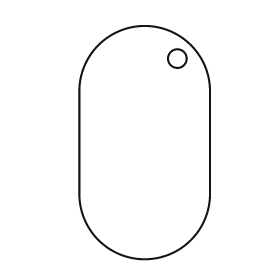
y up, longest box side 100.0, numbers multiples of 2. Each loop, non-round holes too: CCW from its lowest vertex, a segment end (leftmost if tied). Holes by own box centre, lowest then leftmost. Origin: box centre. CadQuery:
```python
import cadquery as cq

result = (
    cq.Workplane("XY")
    .moveTo(-28.0, -22.0)
    .threePointArc((0.0, -50.0), (28.0, -22.0))
    .lineTo(28.0, 22.0)
    .threePointArc((0.0, 50.0), (-28.0, 22.0))
    .close()
    .moveTo(14.0, 36.0)
    .circle(4.0)
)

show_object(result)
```